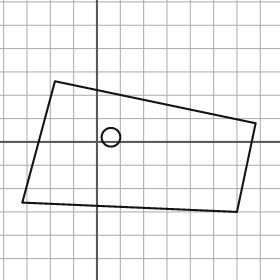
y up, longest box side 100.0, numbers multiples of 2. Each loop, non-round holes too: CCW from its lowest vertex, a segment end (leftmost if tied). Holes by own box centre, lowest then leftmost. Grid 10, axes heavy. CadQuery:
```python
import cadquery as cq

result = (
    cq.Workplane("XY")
    .moveTo(60.0, -30.0)
    .lineTo(68.0, 8.0)
    .lineTo(-18.0, 26.0)
    .lineTo(-32.0, -26.0)
    .close()
    .moveTo(6.0, 2.0)
    .circle(4.0)
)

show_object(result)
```